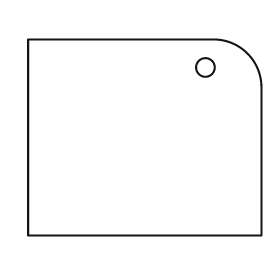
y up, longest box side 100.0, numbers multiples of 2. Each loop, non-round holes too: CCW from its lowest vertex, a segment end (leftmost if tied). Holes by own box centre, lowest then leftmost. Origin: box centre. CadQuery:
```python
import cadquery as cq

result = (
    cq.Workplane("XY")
    .moveTo(-50.0, -42.0)
    .lineTo(50.0, -42.0)
    .lineTo(50.0, 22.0)
    .threePointArc((44.0, 36.0), (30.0, 42.0))
    .lineTo(-50.0, 42.0)
    .close()
    .moveTo(26.0, 30.0)
    .circle(4.0)
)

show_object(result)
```